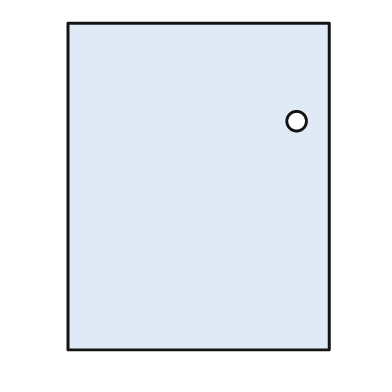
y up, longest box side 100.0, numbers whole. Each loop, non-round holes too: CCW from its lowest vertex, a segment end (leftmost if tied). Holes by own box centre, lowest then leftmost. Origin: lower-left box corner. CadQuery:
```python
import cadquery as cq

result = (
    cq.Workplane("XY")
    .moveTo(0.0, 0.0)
    .lineTo(80.0, 0.0)
    .lineTo(80.0, 100.0)
    .lineTo(0.0, 100.0)
    .close()
    .moveTo(70.0, 70.0)
    .circle(3.0)
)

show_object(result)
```